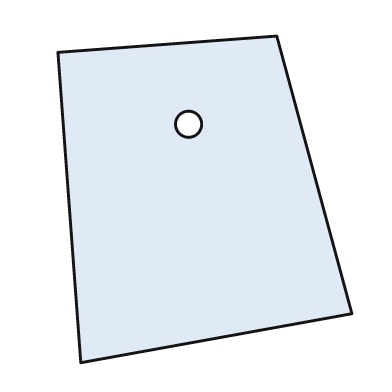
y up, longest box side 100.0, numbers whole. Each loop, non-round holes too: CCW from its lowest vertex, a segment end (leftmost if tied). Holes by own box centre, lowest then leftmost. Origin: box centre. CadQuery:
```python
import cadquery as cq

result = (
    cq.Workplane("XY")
    .moveTo(-38.0, -50.0)
    .lineTo(45.0, -35.0)
    .lineTo(22.0, 50.0)
    .lineTo(-45.0, 45.0)
    .close()
    .moveTo(-5.0, 23.0)
    .circle(4.0)
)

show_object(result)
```